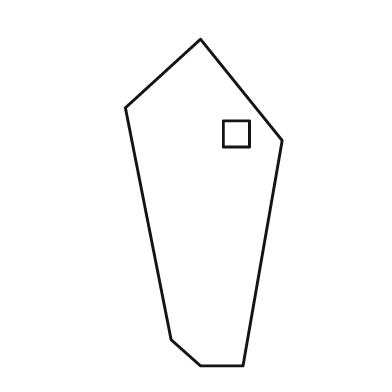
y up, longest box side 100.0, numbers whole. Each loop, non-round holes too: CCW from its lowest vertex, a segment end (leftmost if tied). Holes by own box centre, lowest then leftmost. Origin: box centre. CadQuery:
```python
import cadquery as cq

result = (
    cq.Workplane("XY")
    .moveTo(-1.0, -50.0)
    .lineTo(12.0, -50.0)
    .lineTo(24.0, 19.0)
    .lineTo(-1.0, 50.0)
    .lineTo(-24.0, 29.0)
    .lineTo(-10.0, -42.0)
    .close()
    .moveTo(6.0, 17.0)
    .lineTo(14.0, 17.0)
    .lineTo(14.0, 25.0)
    .lineTo(6.0, 25.0)
    .close()
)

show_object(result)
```